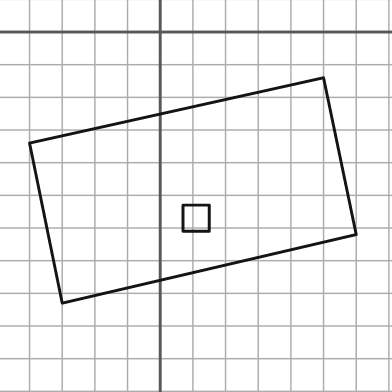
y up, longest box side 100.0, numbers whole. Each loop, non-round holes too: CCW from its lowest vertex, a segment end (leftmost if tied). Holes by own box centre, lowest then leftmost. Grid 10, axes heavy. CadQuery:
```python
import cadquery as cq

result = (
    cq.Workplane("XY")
    .moveTo(-30.0, -83.0)
    .lineTo(60.0, -62.0)
    .lineTo(50.0, -14.0)
    .lineTo(-40.0, -34.0)
    .close()
    .moveTo(7.0, -61.0)
    .lineTo(15.0, -61.0)
    .lineTo(15.0, -53.0)
    .lineTo(7.0, -53.0)
    .close()
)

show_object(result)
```